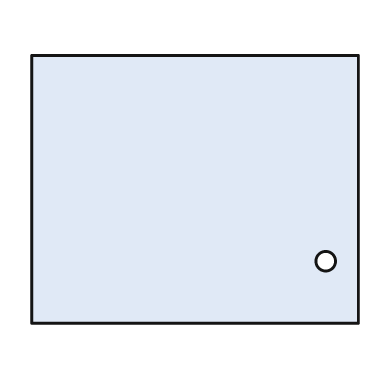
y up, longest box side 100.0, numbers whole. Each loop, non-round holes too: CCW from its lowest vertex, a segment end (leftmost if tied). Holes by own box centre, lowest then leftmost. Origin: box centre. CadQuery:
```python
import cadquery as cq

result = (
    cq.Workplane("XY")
    .moveTo(-50.0, -41.0)
    .lineTo(50.0, -41.0)
    .lineTo(50.0, 41.0)
    .lineTo(-50.0, 41.0)
    .close()
    .moveTo(40.0, -22.0)
    .circle(3.0)
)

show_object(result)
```